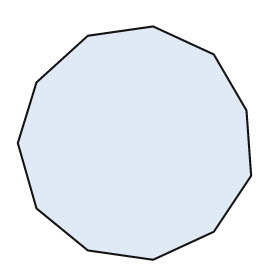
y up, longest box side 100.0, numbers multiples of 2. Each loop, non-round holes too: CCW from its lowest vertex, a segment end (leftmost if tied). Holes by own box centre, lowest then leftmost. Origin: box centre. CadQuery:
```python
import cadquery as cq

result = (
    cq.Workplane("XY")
    .moveTo(8.0, -50.0)
    .lineTo(34.0, -38.0)
    .lineTo(50.0, -14.0)
    .lineTo(48.0, 14.0)
    .lineTo(34.0, 38.0)
    .lineTo(8.0, 50.0)
    .lineTo(-20.0, 46.0)
    .lineTo(-42.0, 26.0)
    .lineTo(-50.0, 0.0)
    .lineTo(-42.0, -28.0)
    .lineTo(-20.0, -46.0)
    .close()
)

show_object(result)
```